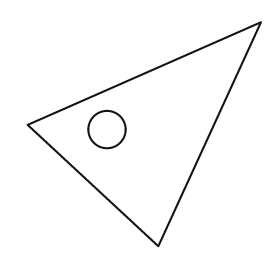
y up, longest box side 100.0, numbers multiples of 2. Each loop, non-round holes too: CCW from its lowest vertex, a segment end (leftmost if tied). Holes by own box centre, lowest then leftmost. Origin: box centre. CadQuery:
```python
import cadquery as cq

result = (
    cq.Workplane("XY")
    .moveTo(6.0, -48.0)
    .lineTo(50.0, 48.0)
    .lineTo(-50.0, 4.0)
    .close()
    .moveTo(-16.0, 2.0)
    .circle(8.0)
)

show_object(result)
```